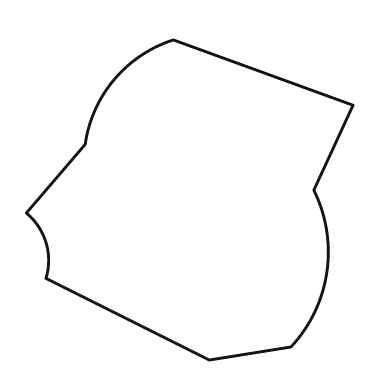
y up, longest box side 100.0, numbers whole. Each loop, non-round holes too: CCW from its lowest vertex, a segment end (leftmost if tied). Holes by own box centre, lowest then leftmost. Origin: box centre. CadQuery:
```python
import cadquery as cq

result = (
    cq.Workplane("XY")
    .moveTo(6.0, -49.0)
    .lineTo(31.0, -45.0)
    .threePointArc((42.0, -22.0), (38.0, 3.0))
    .lineTo(50.0, 29.0)
    .lineTo(-5.0, 49.0)
    .threePointArc((-23.0, 37.0), (-32.0, 17.0))
    .lineTo(-50.0, -4.0)
    .threePointArc((-44.0, -13.0), (-44.0, -24.0))
    .close()
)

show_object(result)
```